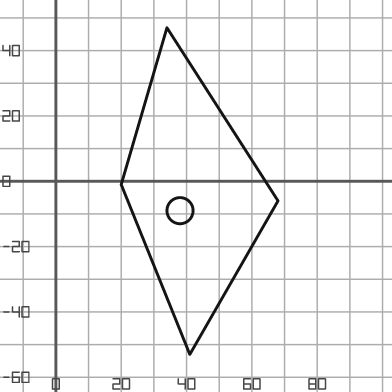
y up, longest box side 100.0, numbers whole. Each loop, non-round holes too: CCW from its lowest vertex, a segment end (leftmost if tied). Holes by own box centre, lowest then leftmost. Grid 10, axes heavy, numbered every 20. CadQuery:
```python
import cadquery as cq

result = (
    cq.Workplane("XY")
    .moveTo(41.0, -53.0)
    .lineTo(68.0, -6.0)
    .lineTo(34.0, 47.0)
    .lineTo(20.0, -1.0)
    .close()
    .moveTo(38.0, -9.0)
    .circle(4.0)
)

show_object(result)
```